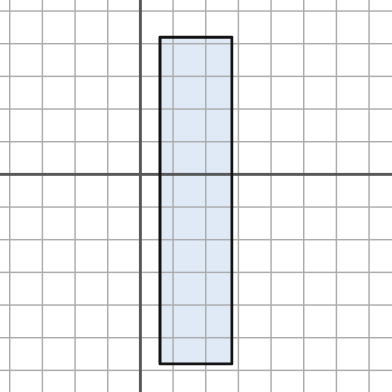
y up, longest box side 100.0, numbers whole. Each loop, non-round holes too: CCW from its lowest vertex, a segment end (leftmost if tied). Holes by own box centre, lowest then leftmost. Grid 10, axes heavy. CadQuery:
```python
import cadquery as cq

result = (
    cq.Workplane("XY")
    .moveTo(6.0, -58.0)
    .lineTo(28.0, -58.0)
    .lineTo(28.0, 42.0)
    .lineTo(6.0, 42.0)
    .close()
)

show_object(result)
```